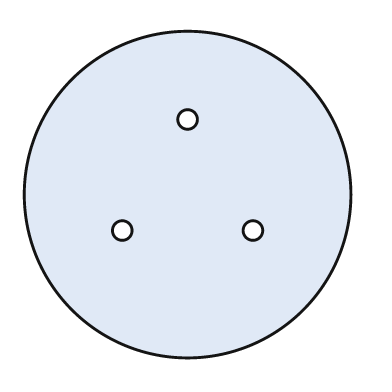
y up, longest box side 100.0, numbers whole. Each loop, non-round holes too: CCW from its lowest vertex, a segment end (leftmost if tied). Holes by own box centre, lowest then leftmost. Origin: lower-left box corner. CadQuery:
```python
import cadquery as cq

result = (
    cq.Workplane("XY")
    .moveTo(50.0, 50.0)
    .circle(50.0)
    .moveTo(30.0, 39.0)
    .circle(3.0)
    .moveTo(70.0, 39.0)
    .circle(3.0)
    .moveTo(50.0, 73.0)
    .circle(3.0)
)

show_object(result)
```